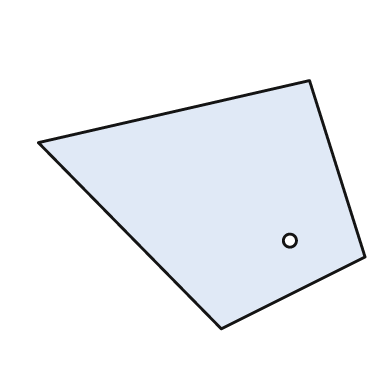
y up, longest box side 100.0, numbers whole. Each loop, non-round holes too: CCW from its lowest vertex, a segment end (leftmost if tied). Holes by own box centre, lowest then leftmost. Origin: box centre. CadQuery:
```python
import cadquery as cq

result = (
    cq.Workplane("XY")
    .moveTo(6.0, -38.0)
    .lineTo(50.0, -16.0)
    .lineTo(33.0, 38.0)
    .lineTo(-50.0, 19.0)
    .close()
    .moveTo(27.0, -11.0)
    .circle(2.0)
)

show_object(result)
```